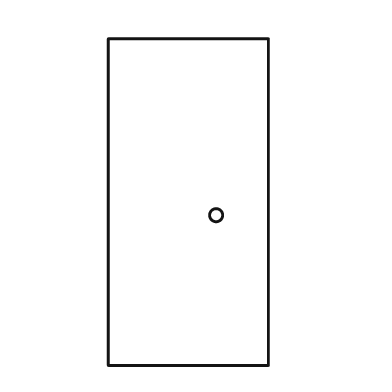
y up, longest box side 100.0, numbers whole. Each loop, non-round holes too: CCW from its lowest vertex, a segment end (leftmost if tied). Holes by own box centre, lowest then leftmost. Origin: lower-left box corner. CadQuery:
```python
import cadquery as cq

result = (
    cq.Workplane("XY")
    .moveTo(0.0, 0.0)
    .lineTo(49.0, 0.0)
    .lineTo(49.0, 100.0)
    .lineTo(0.0, 100.0)
    .close()
    .moveTo(33.0, 46.0)
    .circle(2.0)
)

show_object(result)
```